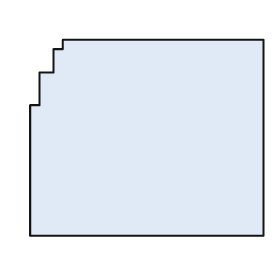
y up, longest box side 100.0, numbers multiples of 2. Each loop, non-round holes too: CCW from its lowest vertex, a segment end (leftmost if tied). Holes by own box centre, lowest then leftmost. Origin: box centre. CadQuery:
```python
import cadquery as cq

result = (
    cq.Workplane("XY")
    .moveTo(-50.0, -42.0)
    .lineTo(50.0, -42.0)
    .lineTo(50.0, 42.0)
    .lineTo(-36.0, 42.0)
    .lineTo(-36.0, 38.0)
    .lineTo(-40.0, 38.0)
    .lineTo(-40.0, 28.0)
    .lineTo(-46.0, 28.0)
    .lineTo(-46.0, 14.0)
    .lineTo(-50.0, 14.0)
    .close()
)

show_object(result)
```